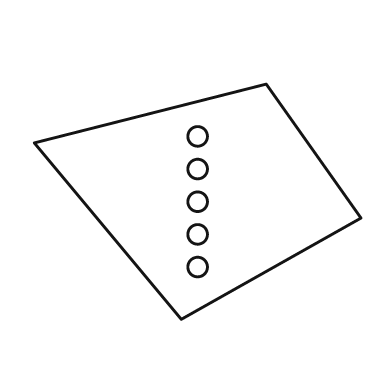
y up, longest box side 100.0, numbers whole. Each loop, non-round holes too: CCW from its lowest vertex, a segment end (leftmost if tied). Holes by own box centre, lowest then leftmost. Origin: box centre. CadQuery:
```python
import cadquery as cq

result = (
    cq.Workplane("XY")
    .moveTo(-5.0, -36.0)
    .lineTo(50.0, -5.0)
    .lineTo(21.0, 36.0)
    .lineTo(-50.0, 18.0)
    .close()
    .moveTo(0.0, -20.0)
    .circle(3.0)
    .moveTo(0.0, -10.0)
    .circle(3.0)
    .moveTo(0.0, 0.0)
    .circle(3.0)
    .moveTo(0.0, 10.0)
    .circle(3.0)
    .moveTo(0.0, 20.0)
    .circle(3.0)
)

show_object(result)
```